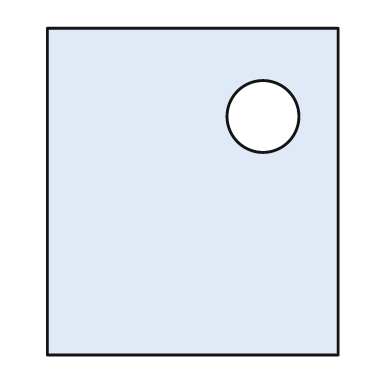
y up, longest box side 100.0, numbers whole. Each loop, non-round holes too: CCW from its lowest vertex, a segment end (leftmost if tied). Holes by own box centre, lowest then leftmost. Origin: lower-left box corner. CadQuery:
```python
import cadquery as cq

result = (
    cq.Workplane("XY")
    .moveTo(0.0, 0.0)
    .lineTo(89.0, 0.0)
    .lineTo(89.0, 100.0)
    .lineTo(0.0, 100.0)
    .close()
    .moveTo(66.0, 73.0)
    .circle(11.0)
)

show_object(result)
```